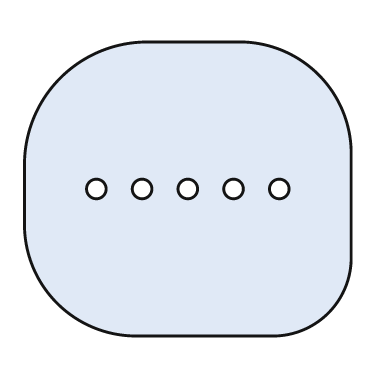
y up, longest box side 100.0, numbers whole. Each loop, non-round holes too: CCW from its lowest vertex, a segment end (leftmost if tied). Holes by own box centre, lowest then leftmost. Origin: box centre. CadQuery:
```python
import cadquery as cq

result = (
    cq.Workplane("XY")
    .moveTo(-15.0, -45.0)
    .lineTo(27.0, -45.0)
    .threePointArc((43.0, -38.0), (50.0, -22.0))
    .lineTo(50.0, 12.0)
    .threePointArc((40.0, 35.0), (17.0, 45.0))
    .lineTo(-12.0, 45.0)
    .threePointArc((-39.0, 34.0), (-50.0, 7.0))
    .lineTo(-50.0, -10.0)
    .threePointArc((-40.0, -35.0), (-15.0, -45.0))
    .close()
    .moveTo(-28.0, 0.0)
    .circle(3.0)
    .moveTo(-14.0, 0.0)
    .circle(3.0)
    .moveTo(0.0, 0.0)
    .circle(3.0)
    .moveTo(14.0, 0.0)
    .circle(3.0)
    .moveTo(28.0, 0.0)
    .circle(3.0)
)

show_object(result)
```